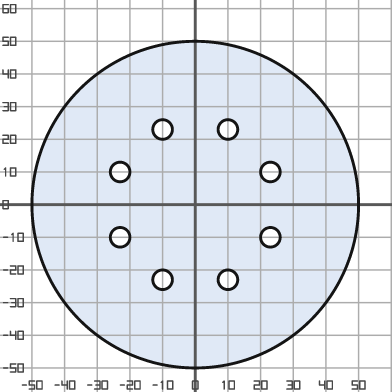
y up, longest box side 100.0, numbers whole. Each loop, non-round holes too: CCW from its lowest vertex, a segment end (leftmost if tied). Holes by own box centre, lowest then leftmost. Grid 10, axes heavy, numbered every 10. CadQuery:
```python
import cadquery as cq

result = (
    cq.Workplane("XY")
    .moveTo(0.0, 0.0)
    .circle(50.0)
    .moveTo(-10.0, -23.0)
    .circle(3.0)
    .moveTo(10.0, -23.0)
    .circle(3.0)
    .moveTo(-23.0, -10.0)
    .circle(3.0)
    .moveTo(23.0, -10.0)
    .circle(3.0)
    .moveTo(-23.0, 10.0)
    .circle(3.0)
    .moveTo(23.0, 10.0)
    .circle(3.0)
    .moveTo(-10.0, 23.0)
    .circle(3.0)
    .moveTo(10.0, 23.0)
    .circle(3.0)
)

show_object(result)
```